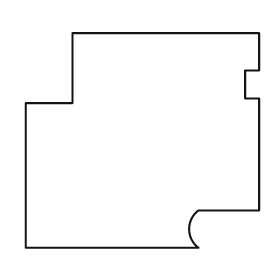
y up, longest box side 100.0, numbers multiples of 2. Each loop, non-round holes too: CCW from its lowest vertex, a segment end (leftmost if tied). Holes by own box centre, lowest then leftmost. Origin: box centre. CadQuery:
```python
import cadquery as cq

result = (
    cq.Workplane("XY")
    .moveTo(-50.0, -46.0)
    .lineTo(24.0, -46.0)
    .threePointArc((20.0, -38.0), (24.0, -30.0))
    .lineTo(50.0, -30.0)
    .lineTo(50.0, 18.0)
    .lineTo(44.0, 18.0)
    .lineTo(44.0, 30.0)
    .lineTo(50.0, 30.0)
    .lineTo(50.0, 46.0)
    .lineTo(-30.0, 46.0)
    .lineTo(-30.0, 16.0)
    .lineTo(-50.0, 16.0)
    .close()
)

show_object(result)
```